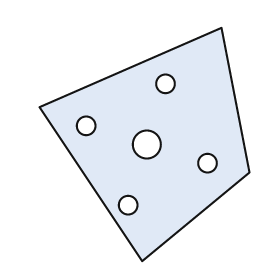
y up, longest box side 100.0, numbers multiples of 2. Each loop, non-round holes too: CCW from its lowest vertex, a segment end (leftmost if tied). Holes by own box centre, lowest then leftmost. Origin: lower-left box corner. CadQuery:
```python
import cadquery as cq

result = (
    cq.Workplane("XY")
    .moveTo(44.0, 0.0)
    .lineTo(90.0, 38.0)
    .lineTo(78.0, 100.0)
    .lineTo(0.0, 66.0)
    .close()
    .moveTo(38.0, 24.0)
    .circle(4.0)
    .moveTo(72.0, 42.0)
    .circle(4.0)
    .moveTo(46.0, 50.0)
    .circle(6.0)
    .moveTo(20.0, 58.0)
    .circle(4.0)
    .moveTo(54.0, 76.0)
    .circle(4.0)
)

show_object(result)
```